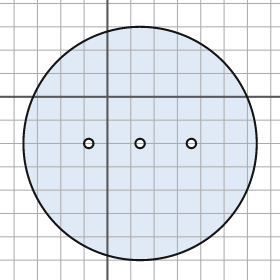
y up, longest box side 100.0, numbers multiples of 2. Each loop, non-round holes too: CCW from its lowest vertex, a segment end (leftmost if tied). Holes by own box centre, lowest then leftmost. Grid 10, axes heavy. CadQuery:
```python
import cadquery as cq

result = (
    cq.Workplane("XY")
    .moveTo(14.0, -20.0)
    .circle(50.0)
    .moveTo(-8.0, -20.0)
    .circle(2.0)
    .moveTo(14.0, -20.0)
    .circle(2.0)
    .moveTo(36.0, -20.0)
    .circle(2.0)
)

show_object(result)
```